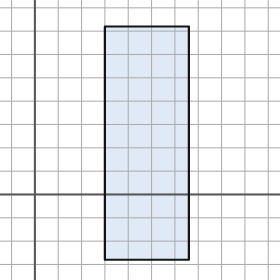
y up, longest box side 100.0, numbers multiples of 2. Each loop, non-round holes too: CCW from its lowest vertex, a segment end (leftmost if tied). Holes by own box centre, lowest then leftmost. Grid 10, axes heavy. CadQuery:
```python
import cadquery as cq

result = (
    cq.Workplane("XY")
    .moveTo(30.0, -28.0)
    .lineTo(66.0, -28.0)
    .lineTo(66.0, 72.0)
    .lineTo(30.0, 72.0)
    .close()
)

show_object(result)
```